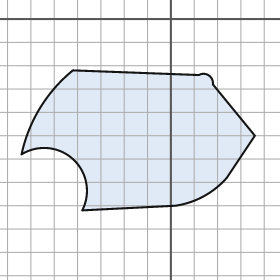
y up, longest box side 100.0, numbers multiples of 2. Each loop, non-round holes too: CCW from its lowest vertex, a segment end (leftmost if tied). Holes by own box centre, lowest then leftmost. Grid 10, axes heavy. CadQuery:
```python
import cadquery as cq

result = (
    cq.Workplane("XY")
    .moveTo(-38.0, -82.0)
    .lineTo(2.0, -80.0)
    .threePointArc((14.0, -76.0), (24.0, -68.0))
    .lineTo(36.0, -50.0)
    .lineTo(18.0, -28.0)
    .threePointArc((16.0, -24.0), (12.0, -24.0))
    .lineTo(-42.0, -22.0)
    .threePointArc((-56.0, -38.0), (-64.0, -58.0))
    .threePointArc((-42.0, -60.0), (-38.0, -82.0))
    .close()
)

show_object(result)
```